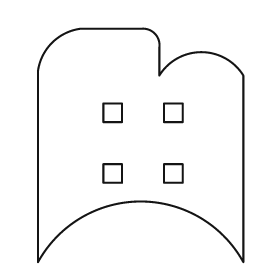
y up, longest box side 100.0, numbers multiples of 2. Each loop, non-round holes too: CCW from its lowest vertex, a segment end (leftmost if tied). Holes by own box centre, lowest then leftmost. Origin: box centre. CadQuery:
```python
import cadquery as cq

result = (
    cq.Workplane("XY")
    .moveTo(-44.0, -50.0)
    .threePointArc((0.0, -24.0), (44.0, -50.0))
    .lineTo(44.0, 30.0)
    .threePointArc((26.0, 40.0), (8.0, 30.0))
    .lineTo(8.0, 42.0)
    .threePointArc((6.0, 48.0), (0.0, 50.0))
    .lineTo(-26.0, 50.0)
    .threePointArc((-38.0, 44.0), (-44.0, 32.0))
    .close()
    .moveTo(-16.0, -16.0)
    .lineTo(-8.0, -16.0)
    .lineTo(-8.0, -8.0)
    .lineTo(-16.0, -8.0)
    .close()
    .moveTo(10.0, -16.0)
    .lineTo(18.0, -16.0)
    .lineTo(18.0, -8.0)
    .lineTo(10.0, -8.0)
    .close()
    .moveTo(-16.0, 10.0)
    .lineTo(-8.0, 10.0)
    .lineTo(-8.0, 18.0)
    .lineTo(-16.0, 18.0)
    .close()
    .moveTo(10.0, 10.0)
    .lineTo(18.0, 10.0)
    .lineTo(18.0, 18.0)
    .lineTo(10.0, 18.0)
    .close()
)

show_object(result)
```